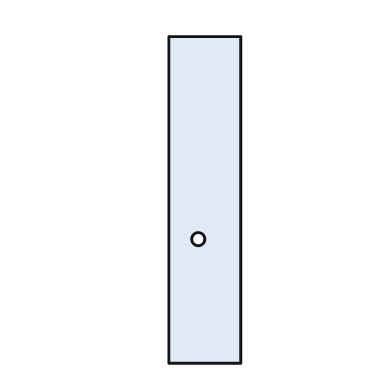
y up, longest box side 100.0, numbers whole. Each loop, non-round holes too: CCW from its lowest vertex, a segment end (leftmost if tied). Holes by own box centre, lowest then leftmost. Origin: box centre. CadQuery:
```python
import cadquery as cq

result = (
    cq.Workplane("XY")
    .moveTo(-11.0, -50.0)
    .lineTo(11.0, -50.0)
    .lineTo(11.0, 50.0)
    .lineTo(-11.0, 50.0)
    .close()
    .moveTo(-2.0, -12.0)
    .circle(2.0)
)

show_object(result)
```